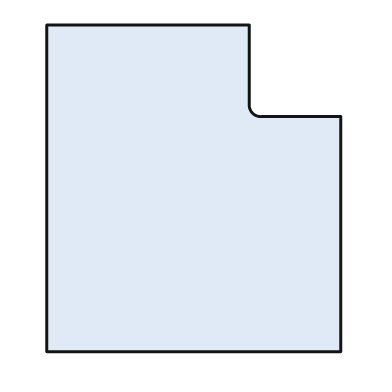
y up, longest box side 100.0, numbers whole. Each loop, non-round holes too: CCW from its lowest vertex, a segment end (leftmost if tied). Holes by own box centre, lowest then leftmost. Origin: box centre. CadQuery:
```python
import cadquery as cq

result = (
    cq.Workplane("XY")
    .moveTo(-45.0, -50.0)
    .lineTo(45.0, -50.0)
    .lineTo(45.0, 22.0)
    .lineTo(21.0, 22.0)
    .threePointArc((18.0, 23.0), (17.0, 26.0))
    .lineTo(17.0, 50.0)
    .lineTo(-45.0, 50.0)
    .close()
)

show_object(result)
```